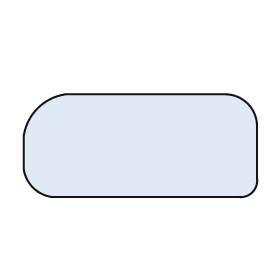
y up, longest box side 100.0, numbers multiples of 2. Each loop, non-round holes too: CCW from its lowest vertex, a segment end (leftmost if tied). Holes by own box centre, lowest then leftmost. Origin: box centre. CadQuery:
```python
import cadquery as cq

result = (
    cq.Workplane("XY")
    .moveTo(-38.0, -22.0)
    .lineTo(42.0, -22.0)
    .threePointArc((48.0, -20.0), (50.0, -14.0))
    .lineTo(50.0, 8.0)
    .threePointArc((46.0, 18.0), (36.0, 22.0))
    .lineTo(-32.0, 22.0)
    .threePointArc((-44.0, 16.0), (-50.0, 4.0))
    .lineTo(-50.0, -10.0)
    .threePointArc((-46.0, -18.0), (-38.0, -22.0))
    .close()
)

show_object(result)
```